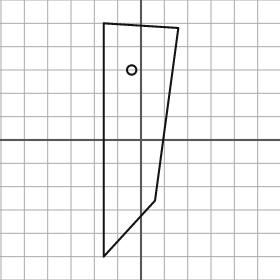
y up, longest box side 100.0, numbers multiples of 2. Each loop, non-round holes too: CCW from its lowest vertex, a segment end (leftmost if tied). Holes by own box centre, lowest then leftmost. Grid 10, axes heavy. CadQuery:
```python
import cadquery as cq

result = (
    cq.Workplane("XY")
    .moveTo(-16.0, -50.0)
    .lineTo(6.0, -26.0)
    .lineTo(16.0, 48.0)
    .lineTo(-16.0, 50.0)
    .close()
    .moveTo(-4.0, 30.0)
    .circle(2.0)
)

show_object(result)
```